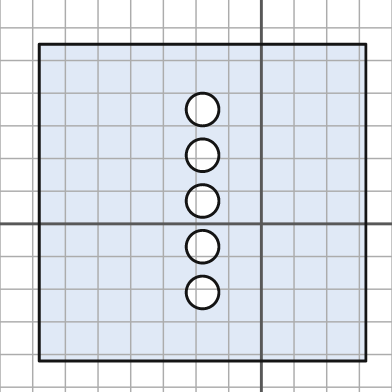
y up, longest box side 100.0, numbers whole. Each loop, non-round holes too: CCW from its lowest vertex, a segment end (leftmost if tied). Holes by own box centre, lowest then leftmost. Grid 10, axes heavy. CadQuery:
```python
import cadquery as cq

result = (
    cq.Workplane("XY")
    .moveTo(-68.0, -42.0)
    .lineTo(32.0, -42.0)
    .lineTo(32.0, 55.0)
    .lineTo(-68.0, 55.0)
    .close()
    .moveTo(-18.0, -21.0)
    .circle(5.0)
    .moveTo(-18.0, -7.0)
    .circle(5.0)
    .moveTo(-18.0, 7.0)
    .circle(5.0)
    .moveTo(-18.0, 21.0)
    .circle(5.0)
    .moveTo(-18.0, 35.0)
    .circle(5.0)
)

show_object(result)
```